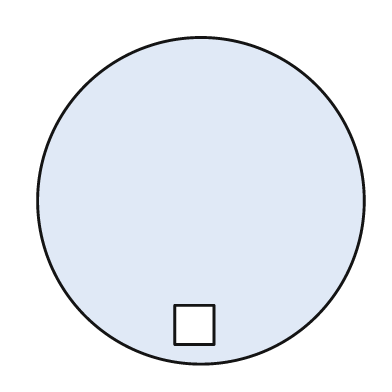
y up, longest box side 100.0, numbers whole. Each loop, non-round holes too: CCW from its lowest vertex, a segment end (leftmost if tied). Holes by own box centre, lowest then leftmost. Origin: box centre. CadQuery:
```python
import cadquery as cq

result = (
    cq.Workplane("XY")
    .moveTo(0.0, 0.0)
    .circle(50.0)
    .moveTo(-8.0, -44.0)
    .lineTo(4.0, -44.0)
    .lineTo(4.0, -32.0)
    .lineTo(-8.0, -32.0)
    .close()
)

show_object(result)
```